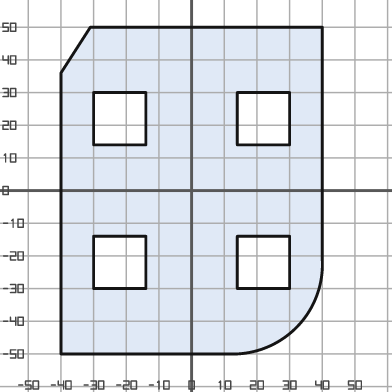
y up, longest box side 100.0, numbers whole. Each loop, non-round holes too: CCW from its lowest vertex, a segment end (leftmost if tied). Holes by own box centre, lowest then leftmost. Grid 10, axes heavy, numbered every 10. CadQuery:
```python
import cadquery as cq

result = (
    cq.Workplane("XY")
    .moveTo(-40.0, -50.0)
    .lineTo(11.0, -50.0)
    .threePointArc((32.0, -42.0), (40.0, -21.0))
    .lineTo(40.0, 50.0)
    .lineTo(-31.0, 50.0)
    .lineTo(-40.0, 36.0)
    .close()
    .moveTo(-30.0, -30.0)
    .lineTo(-14.0, -30.0)
    .lineTo(-14.0, -14.0)
    .lineTo(-30.0, -14.0)
    .close()
    .moveTo(14.0, -30.0)
    .lineTo(30.0, -30.0)
    .lineTo(30.0, -14.0)
    .lineTo(14.0, -14.0)
    .close()
    .moveTo(-30.0, 14.0)
    .lineTo(-14.0, 14.0)
    .lineTo(-14.0, 30.0)
    .lineTo(-30.0, 30.0)
    .close()
    .moveTo(14.0, 14.0)
    .lineTo(30.0, 14.0)
    .lineTo(30.0, 30.0)
    .lineTo(14.0, 30.0)
    .close()
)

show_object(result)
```